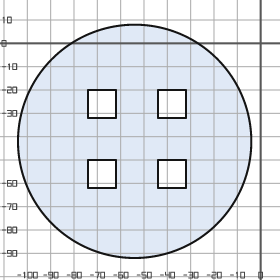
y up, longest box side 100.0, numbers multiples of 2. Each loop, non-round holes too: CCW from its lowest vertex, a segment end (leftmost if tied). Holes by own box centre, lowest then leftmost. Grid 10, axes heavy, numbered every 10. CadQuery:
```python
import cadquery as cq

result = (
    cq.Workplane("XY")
    .moveTo(-54.0, -42.0)
    .circle(50.0)
    .moveTo(-74.0, -62.0)
    .lineTo(-62.0, -62.0)
    .lineTo(-62.0, -50.0)
    .lineTo(-74.0, -50.0)
    .close()
    .moveTo(-44.0, -62.0)
    .lineTo(-32.0, -62.0)
    .lineTo(-32.0, -50.0)
    .lineTo(-44.0, -50.0)
    .close()
    .moveTo(-74.0, -32.0)
    .lineTo(-62.0, -32.0)
    .lineTo(-62.0, -20.0)
    .lineTo(-74.0, -20.0)
    .close()
    .moveTo(-44.0, -32.0)
    .lineTo(-32.0, -32.0)
    .lineTo(-32.0, -20.0)
    .lineTo(-44.0, -20.0)
    .close()
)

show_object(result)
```